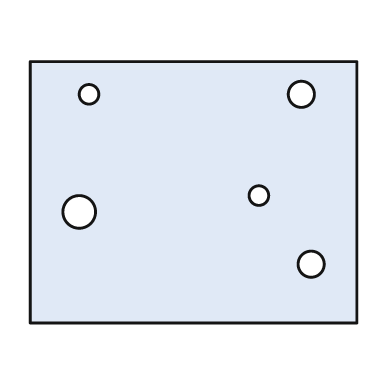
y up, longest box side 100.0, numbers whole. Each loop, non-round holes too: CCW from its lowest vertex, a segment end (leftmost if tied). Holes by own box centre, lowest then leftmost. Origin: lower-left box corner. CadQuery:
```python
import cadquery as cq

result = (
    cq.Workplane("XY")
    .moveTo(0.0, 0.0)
    .lineTo(100.0, 0.0)
    .lineTo(100.0, 80.0)
    .lineTo(0.0, 80.0)
    .close()
    .moveTo(86.0, 18.0)
    .circle(4.0)
    .moveTo(15.0, 34.0)
    .circle(5.0)
    .moveTo(70.0, 39.0)
    .circle(3.0)
    .moveTo(18.0, 70.0)
    .circle(3.0)
    .moveTo(83.0, 70.0)
    .circle(4.0)
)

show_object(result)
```